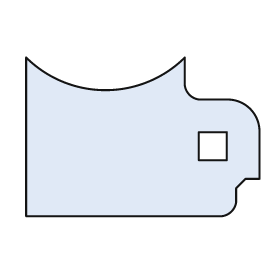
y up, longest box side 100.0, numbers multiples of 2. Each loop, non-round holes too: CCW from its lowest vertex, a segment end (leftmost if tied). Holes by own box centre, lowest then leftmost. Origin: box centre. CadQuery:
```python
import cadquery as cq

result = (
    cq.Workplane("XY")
    .moveTo(-50.0, -34.0)
    .lineTo(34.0, -34.0)
    .threePointArc((38.0, -32.0), (40.0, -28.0))
    .lineTo(40.0, -22.0)
    .lineTo(44.0, -18.0)
    .lineTo(50.0, -18.0)
    .lineTo(50.0, 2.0)
    .threePointArc((46.0, 12.0), (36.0, 16.0))
    .lineTo(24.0, 16.0)
    .threePointArc((20.0, 18.0), (18.0, 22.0))
    .lineTo(18.0, 34.0)
    .threePointArc((-16.0, 20.0), (-50.0, 34.0))
    .close()
    .moveTo(24.0, -10.0)
    .lineTo(36.0, -10.0)
    .lineTo(36.0, 2.0)
    .lineTo(24.0, 2.0)
    .close()
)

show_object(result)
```